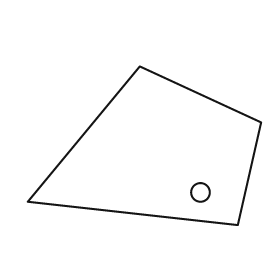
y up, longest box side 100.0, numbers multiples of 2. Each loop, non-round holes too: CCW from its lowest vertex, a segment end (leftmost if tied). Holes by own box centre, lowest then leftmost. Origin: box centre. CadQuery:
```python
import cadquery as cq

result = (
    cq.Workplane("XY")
    .moveTo(40.0, -34.0)
    .lineTo(50.0, 10.0)
    .lineTo(-2.0, 34.0)
    .lineTo(-50.0, -24.0)
    .close()
    .moveTo(24.0, -20.0)
    .circle(4.0)
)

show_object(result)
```